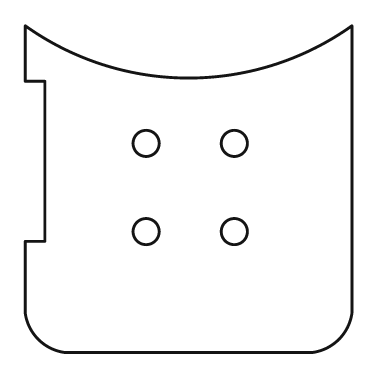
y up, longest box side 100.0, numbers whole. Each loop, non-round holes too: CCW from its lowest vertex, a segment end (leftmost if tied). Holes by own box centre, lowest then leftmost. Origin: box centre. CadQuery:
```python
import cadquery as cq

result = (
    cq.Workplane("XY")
    .moveTo(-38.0, -50.0)
    .lineTo(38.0, -50.0)
    .threePointArc((46.0, -46.0), (50.0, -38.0))
    .lineTo(50.0, 50.0)
    .threePointArc((0.0, 34.0), (-50.0, 50.0))
    .lineTo(-50.0, 33.0)
    .lineTo(-44.0, 33.0)
    .lineTo(-44.0, -16.0)
    .lineTo(-50.0, -16.0)
    .lineTo(-50.0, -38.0)
    .threePointArc((-46.0, -46.0), (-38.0, -50.0))
    .close()
    .moveTo(-13.0, -13.0)
    .circle(4.0)
    .moveTo(14.0, -13.0)
    .circle(4.0)
    .moveTo(-13.0, 14.0)
    .circle(4.0)
    .moveTo(14.0, 14.0)
    .circle(4.0)
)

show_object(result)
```